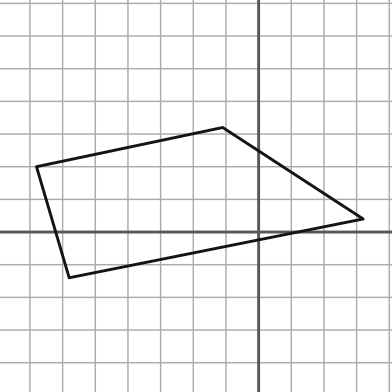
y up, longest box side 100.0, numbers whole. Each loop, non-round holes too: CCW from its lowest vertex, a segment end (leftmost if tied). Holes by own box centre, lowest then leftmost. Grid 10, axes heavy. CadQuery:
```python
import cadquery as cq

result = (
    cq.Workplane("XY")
    .moveTo(-58.0, -14.0)
    .lineTo(32.0, 4.0)
    .lineTo(-11.0, 32.0)
    .lineTo(-68.0, 20.0)
    .close()
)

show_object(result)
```